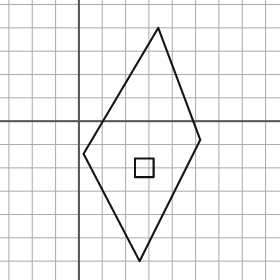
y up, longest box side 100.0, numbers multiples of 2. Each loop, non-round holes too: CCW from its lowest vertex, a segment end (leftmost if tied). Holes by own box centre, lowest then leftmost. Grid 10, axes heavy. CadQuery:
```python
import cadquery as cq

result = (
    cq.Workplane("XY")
    .moveTo(26.0, -60.0)
    .lineTo(52.0, -8.0)
    .lineTo(34.0, 40.0)
    .lineTo(2.0, -14.0)
    .close()
    .moveTo(24.0, -24.0)
    .lineTo(32.0, -24.0)
    .lineTo(32.0, -16.0)
    .lineTo(24.0, -16.0)
    .close()
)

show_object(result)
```